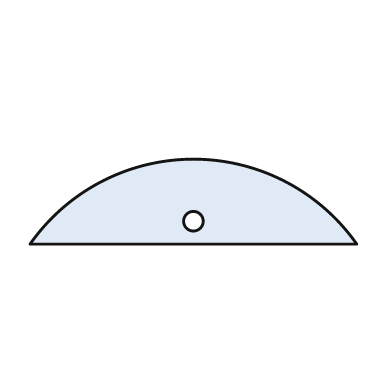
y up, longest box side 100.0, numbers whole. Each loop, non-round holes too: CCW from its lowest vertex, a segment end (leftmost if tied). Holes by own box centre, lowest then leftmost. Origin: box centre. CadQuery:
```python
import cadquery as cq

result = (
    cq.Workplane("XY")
    .moveTo(-50.0, -13.0)
    .lineTo(50.0, -13.0)
    .threePointArc((0.0, 13.0), (-50.0, -13.0))
    .close()
    .moveTo(0.0, -6.0)
    .circle(3.0)
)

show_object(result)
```